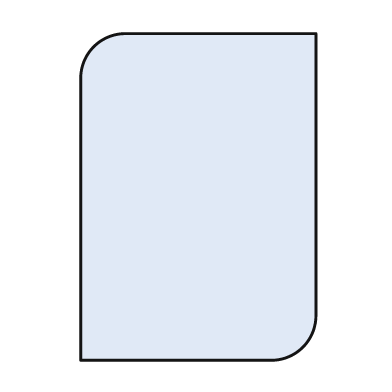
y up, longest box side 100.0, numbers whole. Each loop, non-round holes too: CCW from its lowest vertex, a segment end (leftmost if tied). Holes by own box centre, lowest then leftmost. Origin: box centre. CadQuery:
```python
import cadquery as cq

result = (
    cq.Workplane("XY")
    .moveTo(-36.0, -50.0)
    .lineTo(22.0, -50.0)
    .threePointArc((32.0, -46.0), (36.0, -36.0))
    .lineTo(36.0, 50.0)
    .lineTo(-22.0, 50.0)
    .threePointArc((-32.0, 46.0), (-36.0, 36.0))
    .close()
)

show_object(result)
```